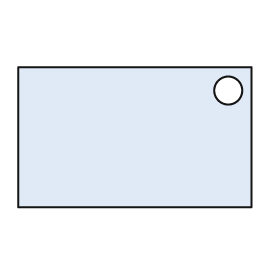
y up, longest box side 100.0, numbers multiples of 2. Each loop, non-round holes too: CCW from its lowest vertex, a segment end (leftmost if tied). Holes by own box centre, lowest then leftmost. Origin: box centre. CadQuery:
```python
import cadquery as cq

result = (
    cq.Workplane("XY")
    .moveTo(-50.0, -30.0)
    .lineTo(50.0, -30.0)
    .lineTo(50.0, 30.0)
    .lineTo(-50.0, 30.0)
    .close()
    .moveTo(40.0, 20.0)
    .circle(6.0)
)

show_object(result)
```